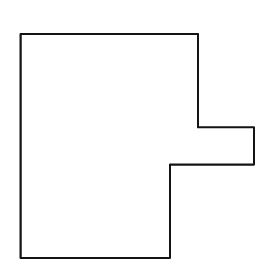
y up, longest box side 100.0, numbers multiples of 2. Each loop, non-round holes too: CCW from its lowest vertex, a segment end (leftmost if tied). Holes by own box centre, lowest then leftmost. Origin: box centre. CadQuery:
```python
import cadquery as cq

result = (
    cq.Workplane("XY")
    .moveTo(-50.0, -48.0)
    .lineTo(14.0, -48.0)
    .lineTo(14.0, -8.0)
    .lineTo(50.0, -8.0)
    .lineTo(50.0, 8.0)
    .lineTo(26.0, 8.0)
    .lineTo(26.0, 48.0)
    .lineTo(-50.0, 48.0)
    .close()
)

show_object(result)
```